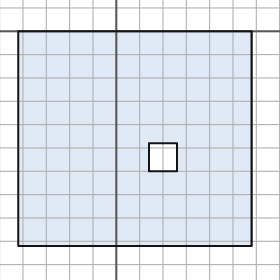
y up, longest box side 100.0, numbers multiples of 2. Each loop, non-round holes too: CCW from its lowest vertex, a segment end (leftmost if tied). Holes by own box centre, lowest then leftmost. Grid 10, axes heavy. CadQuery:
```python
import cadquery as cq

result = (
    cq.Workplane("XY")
    .moveTo(-42.0, -92.0)
    .lineTo(58.0, -92.0)
    .lineTo(58.0, 0.0)
    .lineTo(-42.0, 0.0)
    .close()
    .moveTo(14.0, -60.0)
    .lineTo(26.0, -60.0)
    .lineTo(26.0, -48.0)
    .lineTo(14.0, -48.0)
    .close()
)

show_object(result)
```